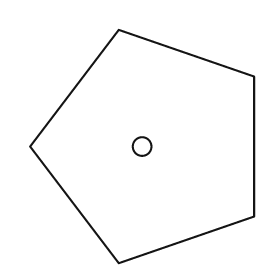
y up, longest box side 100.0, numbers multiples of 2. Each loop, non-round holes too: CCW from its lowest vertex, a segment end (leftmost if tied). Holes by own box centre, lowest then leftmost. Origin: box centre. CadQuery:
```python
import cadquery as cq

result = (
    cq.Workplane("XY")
    .moveTo(-10.0, -50.0)
    .lineTo(48.0, -30.0)
    .lineTo(48.0, 30.0)
    .lineTo(-10.0, 50.0)
    .lineTo(-48.0, 0.0)
    .close()
    .moveTo(0.0, 0.0)
    .circle(4.0)
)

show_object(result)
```